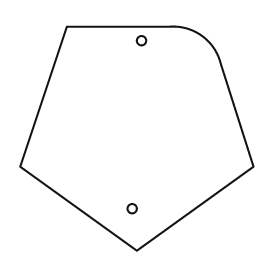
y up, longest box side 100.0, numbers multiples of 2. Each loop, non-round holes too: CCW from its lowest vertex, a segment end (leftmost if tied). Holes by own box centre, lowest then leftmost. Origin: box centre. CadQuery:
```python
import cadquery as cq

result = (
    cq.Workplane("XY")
    .moveTo(0.0, -48.0)
    .lineTo(50.0, -12.0)
    .lineTo(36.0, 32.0)
    .threePointArc((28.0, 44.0), (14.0, 48.0))
    .lineTo(-30.0, 48.0)
    .lineTo(-50.0, -12.0)
    .close()
    .moveTo(-2.0, -30.0)
    .circle(2.0)
    .moveTo(2.0, 42.0)
    .circle(2.0)
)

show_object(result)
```